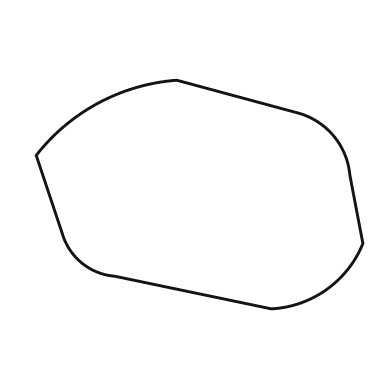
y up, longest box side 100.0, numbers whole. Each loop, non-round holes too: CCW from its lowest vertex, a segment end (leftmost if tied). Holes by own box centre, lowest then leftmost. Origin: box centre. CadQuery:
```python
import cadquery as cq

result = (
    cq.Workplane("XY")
    .moveTo(22.0, -35.0)
    .threePointArc((39.0, -29.0), (50.0, -15.0))
    .lineTo(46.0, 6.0)
    .threePointArc((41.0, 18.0), (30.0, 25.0))
    .lineTo(-7.0, 35.0)
    .threePointArc((-31.0, 28.0), (-50.0, 12.0))
    .lineTo(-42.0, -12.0)
    .threePointArc((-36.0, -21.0), (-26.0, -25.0))
    .close()
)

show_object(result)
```